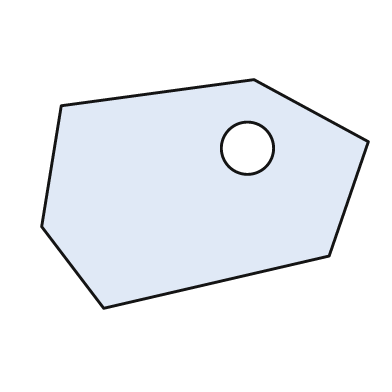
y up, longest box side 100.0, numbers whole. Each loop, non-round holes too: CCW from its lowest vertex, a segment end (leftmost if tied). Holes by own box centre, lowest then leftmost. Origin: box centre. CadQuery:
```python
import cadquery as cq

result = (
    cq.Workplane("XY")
    .moveTo(-31.0, -35.0)
    .lineTo(38.0, -19.0)
    .lineTo(50.0, 16.0)
    .lineTo(15.0, 35.0)
    .lineTo(-44.0, 27.0)
    .lineTo(-50.0, -10.0)
    .close()
    .moveTo(13.0, 14.0)
    .circle(8.0)
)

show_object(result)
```